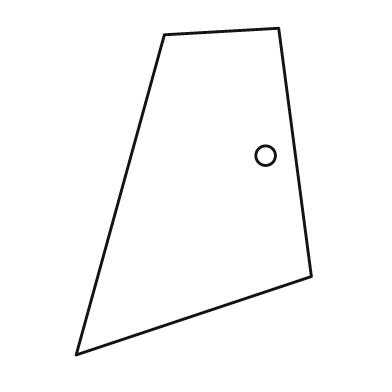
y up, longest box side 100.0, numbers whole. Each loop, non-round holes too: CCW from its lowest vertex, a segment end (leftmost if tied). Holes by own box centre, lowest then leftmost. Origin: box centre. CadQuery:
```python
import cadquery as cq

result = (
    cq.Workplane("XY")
    .moveTo(-36.0, -50.0)
    .lineTo(36.0, -26.0)
    .lineTo(26.0, 50.0)
    .lineTo(-9.0, 48.0)
    .close()
    .moveTo(22.0, 11.0)
    .circle(3.0)
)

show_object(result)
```